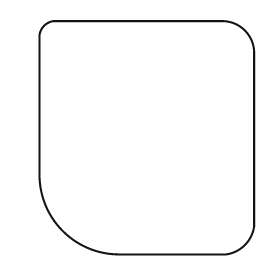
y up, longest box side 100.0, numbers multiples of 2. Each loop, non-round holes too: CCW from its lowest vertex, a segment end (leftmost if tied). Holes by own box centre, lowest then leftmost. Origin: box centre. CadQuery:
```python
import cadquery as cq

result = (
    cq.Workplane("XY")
    .moveTo(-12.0, -50.0)
    .lineTo(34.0, -50.0)
    .threePointArc((42.0, -46.0), (46.0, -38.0))
    .lineTo(46.0, 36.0)
    .threePointArc((42.0, 46.0), (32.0, 50.0))
    .lineTo(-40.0, 50.0)
    .threePointArc((-44.0, 48.0), (-46.0, 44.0))
    .lineTo(-46.0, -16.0)
    .threePointArc((-36.0, -40.0), (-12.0, -50.0))
    .close()
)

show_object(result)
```